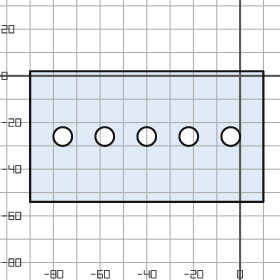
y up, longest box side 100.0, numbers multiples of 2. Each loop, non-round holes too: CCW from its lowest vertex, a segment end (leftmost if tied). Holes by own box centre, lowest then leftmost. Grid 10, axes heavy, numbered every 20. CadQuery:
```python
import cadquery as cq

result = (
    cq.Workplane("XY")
    .moveTo(-90.0, -54.0)
    .lineTo(10.0, -54.0)
    .lineTo(10.0, 2.0)
    .lineTo(-90.0, 2.0)
    .close()
    .moveTo(-76.0, -26.0)
    .circle(4.0)
    .moveTo(-58.0, -26.0)
    .circle(4.0)
    .moveTo(-40.0, -26.0)
    .circle(4.0)
    .moveTo(-22.0, -26.0)
    .circle(4.0)
    .moveTo(-4.0, -26.0)
    .circle(4.0)
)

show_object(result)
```